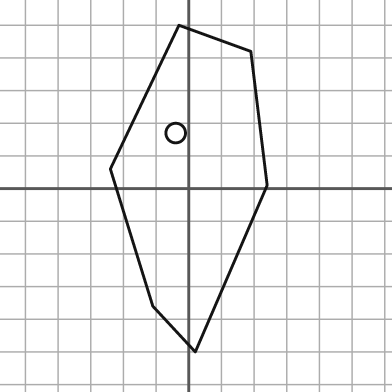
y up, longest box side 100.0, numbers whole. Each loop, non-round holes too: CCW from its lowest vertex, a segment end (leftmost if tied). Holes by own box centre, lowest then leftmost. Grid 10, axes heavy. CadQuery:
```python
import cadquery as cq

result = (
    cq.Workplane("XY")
    .moveTo(2.0, -50.0)
    .lineTo(24.0, 1.0)
    .lineTo(19.0, 42.0)
    .lineTo(-3.0, 50.0)
    .lineTo(-24.0, 6.0)
    .lineTo(-11.0, -36.0)
    .close()
    .moveTo(-4.0, 17.0)
    .circle(3.0)
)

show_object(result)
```